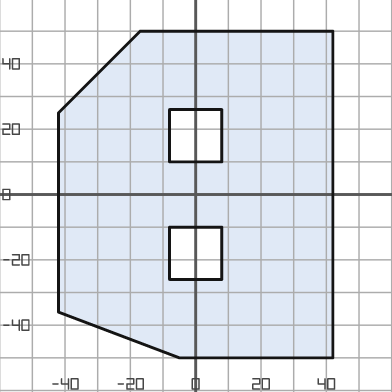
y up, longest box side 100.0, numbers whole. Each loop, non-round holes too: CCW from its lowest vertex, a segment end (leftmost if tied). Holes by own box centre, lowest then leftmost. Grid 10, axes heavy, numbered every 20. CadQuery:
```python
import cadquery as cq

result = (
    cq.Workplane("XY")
    .moveTo(-5.0, -50.0)
    .lineTo(42.0, -50.0)
    .lineTo(42.0, 50.0)
    .lineTo(-17.0, 50.0)
    .lineTo(-42.0, 25.0)
    .lineTo(-42.0, -36.0)
    .close()
    .moveTo(-8.0, -26.0)
    .lineTo(8.0, -26.0)
    .lineTo(8.0, -10.0)
    .lineTo(-8.0, -10.0)
    .close()
    .moveTo(-8.0, 10.0)
    .lineTo(8.0, 10.0)
    .lineTo(8.0, 26.0)
    .lineTo(-8.0, 26.0)
    .close()
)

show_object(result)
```